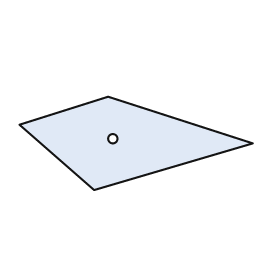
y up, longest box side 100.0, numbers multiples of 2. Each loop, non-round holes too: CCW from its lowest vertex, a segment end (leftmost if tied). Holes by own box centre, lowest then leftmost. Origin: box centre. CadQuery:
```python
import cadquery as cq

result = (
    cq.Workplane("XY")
    .moveTo(-18.0, -20.0)
    .lineTo(50.0, 0.0)
    .lineTo(-12.0, 20.0)
    .lineTo(-50.0, 8.0)
    .close()
    .moveTo(-10.0, 2.0)
    .circle(2.0)
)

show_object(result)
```